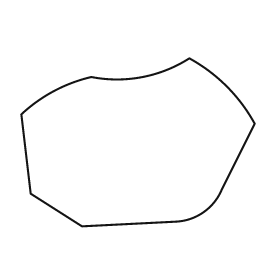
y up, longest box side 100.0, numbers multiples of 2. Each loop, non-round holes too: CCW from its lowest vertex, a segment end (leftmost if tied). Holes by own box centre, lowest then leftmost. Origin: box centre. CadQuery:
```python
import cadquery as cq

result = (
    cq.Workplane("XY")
    .moveTo(-24.0, -36.0)
    .lineTo(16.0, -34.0)
    .threePointArc((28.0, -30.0), (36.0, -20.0))
    .lineTo(50.0, 8.0)
    .threePointArc((38.0, 24.0), (22.0, 36.0))
    .threePointArc((2.0, 28.0), (-20.0, 28.0))
    .threePointArc((-36.0, 22.0), (-50.0, 12.0))
    .lineTo(-46.0, -22.0)
    .close()
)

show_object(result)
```